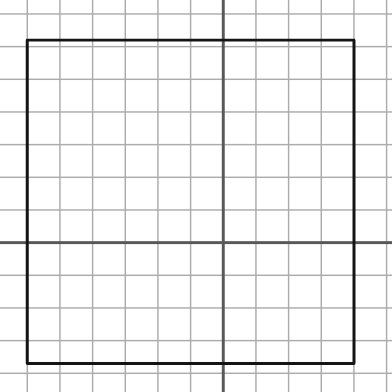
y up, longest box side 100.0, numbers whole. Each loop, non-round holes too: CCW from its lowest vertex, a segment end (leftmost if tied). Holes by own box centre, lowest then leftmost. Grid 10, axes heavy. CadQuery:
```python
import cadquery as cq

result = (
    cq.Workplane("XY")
    .moveTo(-60.0, -37.0)
    .lineTo(40.0, -37.0)
    .lineTo(40.0, 62.0)
    .lineTo(-60.0, 62.0)
    .close()
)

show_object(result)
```